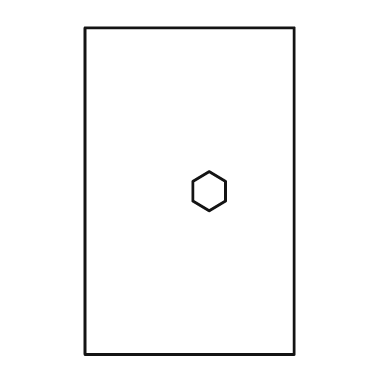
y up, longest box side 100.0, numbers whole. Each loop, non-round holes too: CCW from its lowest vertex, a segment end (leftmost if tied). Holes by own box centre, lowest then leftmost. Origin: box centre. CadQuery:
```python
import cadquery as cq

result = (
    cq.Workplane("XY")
    .moveTo(-32.0, -50.0)
    .lineTo(32.0, -50.0)
    .lineTo(32.0, 50.0)
    .lineTo(-32.0, 50.0)
    .close()
    .moveTo(6.0, -6.0)
    .lineTo(11.0, -3.0)
    .lineTo(11.0, 3.0)
    .lineTo(6.0, 6.0)
    .lineTo(1.0, 3.0)
    .lineTo(1.0, -3.0)
    .close()
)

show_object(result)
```